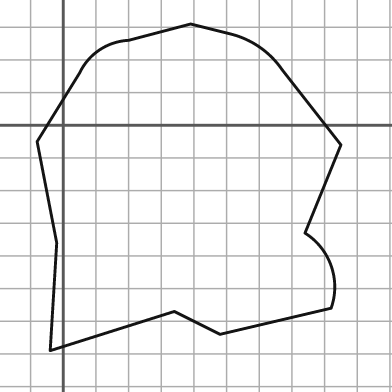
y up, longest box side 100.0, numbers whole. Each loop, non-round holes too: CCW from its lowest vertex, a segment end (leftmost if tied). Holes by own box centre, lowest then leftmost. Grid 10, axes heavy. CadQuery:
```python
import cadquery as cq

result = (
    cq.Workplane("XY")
    .moveTo(-4.0, -69.0)
    .lineTo(34.0, -57.0)
    .lineTo(48.0, -64.0)
    .lineTo(82.0, -56.0)
    .threePointArc((82.0, -43.0), (74.0, -33.0))
    .lineTo(85.0, -6.0)
    .lineTo(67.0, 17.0)
    .threePointArc((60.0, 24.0), (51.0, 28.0))
    .lineTo(39.0, 31.0)
    .lineTo(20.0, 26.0)
    .threePointArc((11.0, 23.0), (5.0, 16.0))
    .lineTo(-8.0, -5.0)
    .lineTo(-2.0, -36.0)
    .close()
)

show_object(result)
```